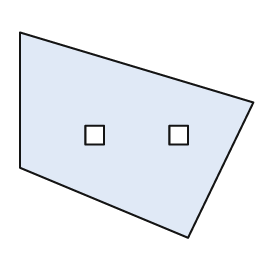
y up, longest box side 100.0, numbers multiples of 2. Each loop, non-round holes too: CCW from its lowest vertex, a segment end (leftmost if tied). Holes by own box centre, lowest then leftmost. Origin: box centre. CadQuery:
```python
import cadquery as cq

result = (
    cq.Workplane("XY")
    .moveTo(22.0, -44.0)
    .lineTo(50.0, 14.0)
    .lineTo(-50.0, 44.0)
    .lineTo(-50.0, -14.0)
    .close()
    .moveTo(-22.0, -4.0)
    .lineTo(-14.0, -4.0)
    .lineTo(-14.0, 4.0)
    .lineTo(-22.0, 4.0)
    .close()
    .moveTo(14.0, -4.0)
    .lineTo(22.0, -4.0)
    .lineTo(22.0, 4.0)
    .lineTo(14.0, 4.0)
    .close()
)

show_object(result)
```